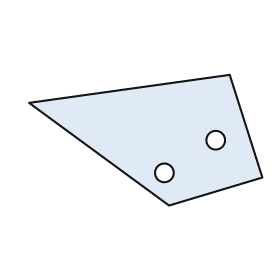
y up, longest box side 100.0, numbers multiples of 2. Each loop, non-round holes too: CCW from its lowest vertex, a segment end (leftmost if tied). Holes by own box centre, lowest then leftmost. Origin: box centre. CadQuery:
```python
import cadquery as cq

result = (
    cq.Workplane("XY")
    .moveTo(10.0, -28.0)
    .lineTo(50.0, -16.0)
    .lineTo(36.0, 28.0)
    .lineTo(-50.0, 16.0)
    .close()
    .moveTo(8.0, -14.0)
    .circle(4.0)
    .moveTo(30.0, 0.0)
    .circle(4.0)
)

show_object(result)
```